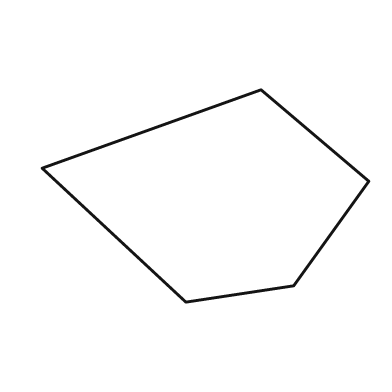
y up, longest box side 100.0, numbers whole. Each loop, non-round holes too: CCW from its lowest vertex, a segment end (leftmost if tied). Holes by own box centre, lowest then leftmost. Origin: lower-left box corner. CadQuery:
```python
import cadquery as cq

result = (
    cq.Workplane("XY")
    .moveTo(44.0, 0.0)
    .lineTo(77.0, 5.0)
    .lineTo(100.0, 37.0)
    .lineTo(67.0, 65.0)
    .lineTo(0.0, 41.0)
    .close()
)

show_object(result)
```